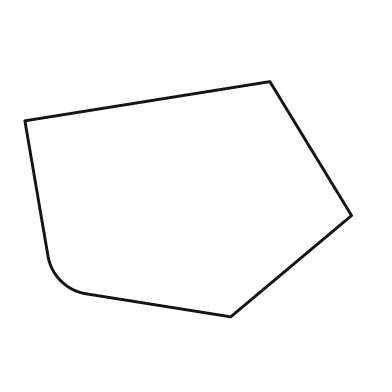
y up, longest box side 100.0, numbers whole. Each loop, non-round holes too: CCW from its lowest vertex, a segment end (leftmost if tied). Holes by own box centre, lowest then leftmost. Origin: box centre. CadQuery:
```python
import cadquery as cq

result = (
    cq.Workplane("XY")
    .moveTo(13.0, -36.0)
    .lineTo(50.0, -5.0)
    .lineTo(25.0, 36.0)
    .lineTo(-50.0, 24.0)
    .lineTo(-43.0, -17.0)
    .threePointArc((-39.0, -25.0), (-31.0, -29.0))
    .close()
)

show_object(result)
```